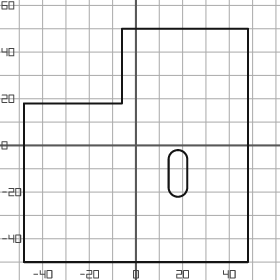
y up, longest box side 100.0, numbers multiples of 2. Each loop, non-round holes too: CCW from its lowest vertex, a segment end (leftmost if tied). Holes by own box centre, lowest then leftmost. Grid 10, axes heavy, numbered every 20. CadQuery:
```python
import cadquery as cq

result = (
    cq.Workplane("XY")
    .moveTo(-48.0, -50.0)
    .lineTo(48.0, -50.0)
    .lineTo(48.0, 50.0)
    .lineTo(-6.0, 50.0)
    .lineTo(-6.0, 18.0)
    .lineTo(-48.0, 18.0)
    .close()
    .moveTo(14.0, -18.0)
    .threePointArc((18.0, -22.0), (22.0, -18.0))
    .lineTo(22.0, -6.0)
    .threePointArc((18.0, -2.0), (14.0, -6.0))
    .close()
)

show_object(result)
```